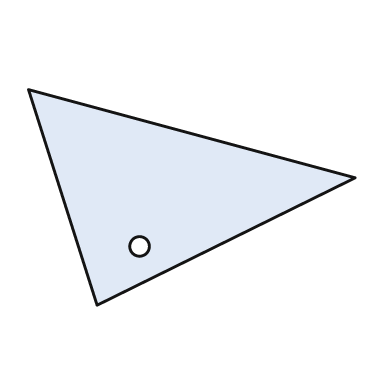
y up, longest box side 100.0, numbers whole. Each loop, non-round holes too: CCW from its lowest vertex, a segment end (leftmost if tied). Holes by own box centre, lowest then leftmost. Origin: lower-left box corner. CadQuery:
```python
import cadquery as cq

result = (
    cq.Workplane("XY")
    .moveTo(21.0, 0.0)
    .lineTo(100.0, 39.0)
    .lineTo(0.0, 66.0)
    .close()
    .moveTo(34.0, 18.0)
    .circle(3.0)
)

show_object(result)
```